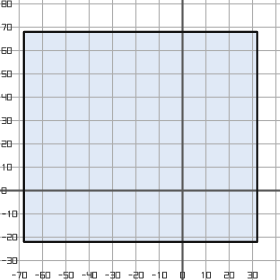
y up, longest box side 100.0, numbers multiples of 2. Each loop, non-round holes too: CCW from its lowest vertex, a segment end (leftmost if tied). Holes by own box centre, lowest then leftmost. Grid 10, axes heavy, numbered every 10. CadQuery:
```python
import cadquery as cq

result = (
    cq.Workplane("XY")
    .moveTo(-68.0, -22.0)
    .lineTo(32.0, -22.0)
    .lineTo(32.0, 68.0)
    .lineTo(-68.0, 68.0)
    .close()
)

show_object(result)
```